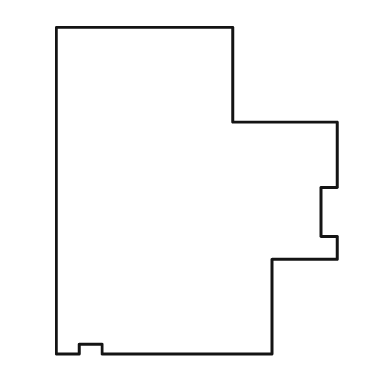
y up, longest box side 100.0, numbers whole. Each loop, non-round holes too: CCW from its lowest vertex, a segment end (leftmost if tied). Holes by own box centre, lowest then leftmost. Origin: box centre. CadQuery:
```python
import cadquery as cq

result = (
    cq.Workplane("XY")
    .moveTo(-43.0, -50.0)
    .lineTo(-36.0, -50.0)
    .lineTo(-36.0, -47.0)
    .lineTo(-29.0, -47.0)
    .lineTo(-29.0, -50.0)
    .lineTo(23.0, -50.0)
    .lineTo(23.0, -21.0)
    .lineTo(43.0, -21.0)
    .lineTo(43.0, -14.0)
    .lineTo(38.0, -14.0)
    .lineTo(38.0, 1.0)
    .lineTo(43.0, 1.0)
    .lineTo(43.0, 21.0)
    .lineTo(11.0, 21.0)
    .lineTo(11.0, 50.0)
    .lineTo(-43.0, 50.0)
    .close()
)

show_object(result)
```